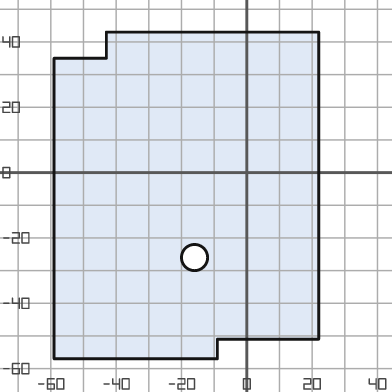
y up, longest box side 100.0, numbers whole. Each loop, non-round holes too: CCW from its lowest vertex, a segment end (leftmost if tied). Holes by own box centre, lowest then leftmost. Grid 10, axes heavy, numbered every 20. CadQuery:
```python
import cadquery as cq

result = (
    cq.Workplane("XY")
    .moveTo(-59.0, -57.0)
    .lineTo(-9.0, -57.0)
    .lineTo(-9.0, -51.0)
    .lineTo(22.0, -51.0)
    .lineTo(22.0, 43.0)
    .lineTo(-43.0, 43.0)
    .lineTo(-43.0, 35.0)
    .lineTo(-59.0, 35.0)
    .close()
    .moveTo(-16.0, -26.0)
    .circle(4.0)
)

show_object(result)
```